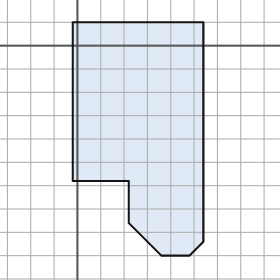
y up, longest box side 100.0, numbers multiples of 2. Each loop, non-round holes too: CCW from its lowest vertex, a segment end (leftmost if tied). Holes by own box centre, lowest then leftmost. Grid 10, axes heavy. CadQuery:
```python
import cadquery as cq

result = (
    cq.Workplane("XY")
    .moveTo(36.0, -90.0)
    .lineTo(48.0, -90.0)
    .lineTo(54.0, -84.0)
    .lineTo(54.0, 10.0)
    .lineTo(-2.0, 10.0)
    .lineTo(-2.0, -58.0)
    .lineTo(22.0, -58.0)
    .lineTo(22.0, -76.0)
    .close()
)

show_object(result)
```